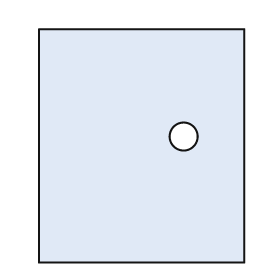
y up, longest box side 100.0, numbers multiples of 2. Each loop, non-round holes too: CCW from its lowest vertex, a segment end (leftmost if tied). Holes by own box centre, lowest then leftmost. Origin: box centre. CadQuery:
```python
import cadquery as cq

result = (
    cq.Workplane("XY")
    .moveTo(-44.0, -50.0)
    .lineTo(44.0, -50.0)
    .lineTo(44.0, 50.0)
    .lineTo(-44.0, 50.0)
    .close()
    .moveTo(18.0, 4.0)
    .circle(6.0)
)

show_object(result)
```